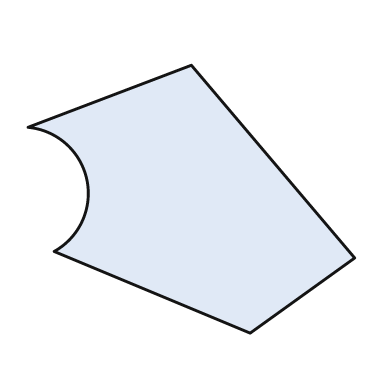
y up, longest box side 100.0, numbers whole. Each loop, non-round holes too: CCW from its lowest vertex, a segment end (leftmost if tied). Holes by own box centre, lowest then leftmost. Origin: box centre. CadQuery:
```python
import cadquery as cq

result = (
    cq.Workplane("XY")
    .moveTo(18.0, -41.0)
    .lineTo(50.0, -18.0)
    .lineTo(0.0, 41.0)
    .lineTo(-50.0, 22.0)
    .threePointArc((-32.0, 6.0), (-42.0, -16.0))
    .close()
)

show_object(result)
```